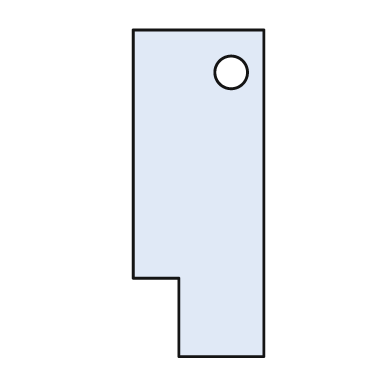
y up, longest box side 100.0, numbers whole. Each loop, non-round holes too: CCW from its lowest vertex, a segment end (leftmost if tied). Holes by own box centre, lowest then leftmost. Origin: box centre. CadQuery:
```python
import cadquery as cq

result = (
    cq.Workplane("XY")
    .moveTo(-6.0, -50.0)
    .lineTo(20.0, -50.0)
    .lineTo(20.0, 50.0)
    .lineTo(-20.0, 50.0)
    .lineTo(-20.0, -26.0)
    .lineTo(-6.0, -26.0)
    .close()
    .moveTo(10.0, 37.0)
    .circle(5.0)
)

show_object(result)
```